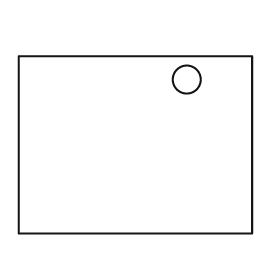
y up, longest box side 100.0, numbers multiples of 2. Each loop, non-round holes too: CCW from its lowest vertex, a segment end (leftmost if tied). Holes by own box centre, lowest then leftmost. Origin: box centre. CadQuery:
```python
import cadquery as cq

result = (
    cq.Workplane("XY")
    .moveTo(-50.0, -38.0)
    .lineTo(50.0, -38.0)
    .lineTo(50.0, 38.0)
    .lineTo(-50.0, 38.0)
    .close()
    .moveTo(22.0, 28.0)
    .circle(6.0)
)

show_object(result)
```